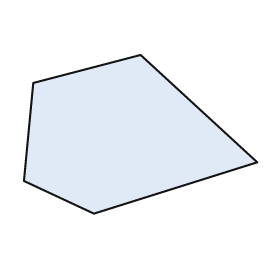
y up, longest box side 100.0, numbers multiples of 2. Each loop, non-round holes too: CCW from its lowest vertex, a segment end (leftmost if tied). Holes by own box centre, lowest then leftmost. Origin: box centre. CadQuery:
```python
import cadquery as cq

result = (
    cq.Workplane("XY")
    .moveTo(-20.0, -34.0)
    .lineTo(50.0, -12.0)
    .lineTo(0.0, 34.0)
    .lineTo(-46.0, 22.0)
    .lineTo(-50.0, -20.0)
    .close()
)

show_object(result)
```